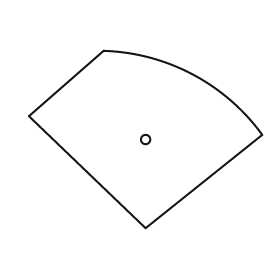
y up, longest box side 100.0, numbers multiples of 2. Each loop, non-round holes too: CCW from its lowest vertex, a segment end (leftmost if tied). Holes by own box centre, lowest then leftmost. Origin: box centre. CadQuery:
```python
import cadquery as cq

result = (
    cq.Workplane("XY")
    .moveTo(0.0, -38.0)
    .lineTo(50.0, 2.0)
    .threePointArc((20.0, 28.0), (-18.0, 38.0))
    .lineTo(-50.0, 10.0)
    .close()
    .moveTo(0.0, 0.0)
    .circle(2.0)
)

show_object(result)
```